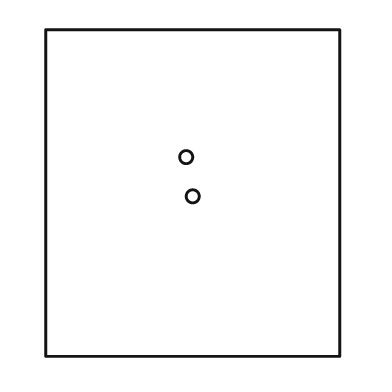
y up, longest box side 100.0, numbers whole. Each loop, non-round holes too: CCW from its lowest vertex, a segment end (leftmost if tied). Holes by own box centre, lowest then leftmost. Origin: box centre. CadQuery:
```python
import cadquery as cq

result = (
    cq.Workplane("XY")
    .moveTo(-45.0, -50.0)
    .lineTo(45.0, -50.0)
    .lineTo(45.0, 50.0)
    .lineTo(-45.0, 50.0)
    .close()
    .moveTo(0.0, -1.0)
    .circle(2.0)
    .moveTo(-2.0, 11.0)
    .circle(2.0)
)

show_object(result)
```